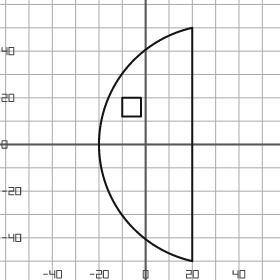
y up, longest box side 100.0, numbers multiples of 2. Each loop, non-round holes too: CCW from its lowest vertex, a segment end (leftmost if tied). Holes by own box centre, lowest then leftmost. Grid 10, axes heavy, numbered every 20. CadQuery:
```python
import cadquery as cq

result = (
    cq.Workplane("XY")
    .moveTo(20.0, -50.0)
    .lineTo(20.0, 50.0)
    .threePointArc((-20.0, 0.0), (20.0, -50.0))
    .close()
    .moveTo(-10.0, 12.0)
    .lineTo(-2.0, 12.0)
    .lineTo(-2.0, 20.0)
    .lineTo(-10.0, 20.0)
    .close()
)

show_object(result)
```